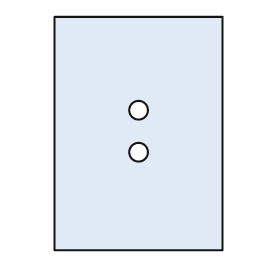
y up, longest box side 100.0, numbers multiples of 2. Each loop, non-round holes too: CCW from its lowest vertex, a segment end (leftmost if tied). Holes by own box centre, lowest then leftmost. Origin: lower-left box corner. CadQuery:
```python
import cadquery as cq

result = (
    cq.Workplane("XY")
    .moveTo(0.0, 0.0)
    .lineTo(72.0, 0.0)
    .lineTo(72.0, 100.0)
    .lineTo(0.0, 100.0)
    .close()
    .moveTo(36.0, 42.0)
    .circle(4.0)
    .moveTo(36.0, 60.0)
    .circle(4.0)
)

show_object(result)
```